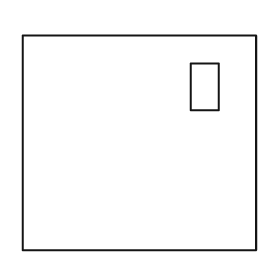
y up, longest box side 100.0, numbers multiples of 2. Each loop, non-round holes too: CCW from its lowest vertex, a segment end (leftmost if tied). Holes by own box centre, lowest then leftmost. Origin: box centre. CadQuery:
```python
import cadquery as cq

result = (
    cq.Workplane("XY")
    .moveTo(-50.0, -46.0)
    .lineTo(50.0, -46.0)
    .lineTo(50.0, 46.0)
    .lineTo(-50.0, 46.0)
    .close()
    .moveTo(22.0, 14.0)
    .lineTo(34.0, 14.0)
    .lineTo(34.0, 34.0)
    .lineTo(22.0, 34.0)
    .close()
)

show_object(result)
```